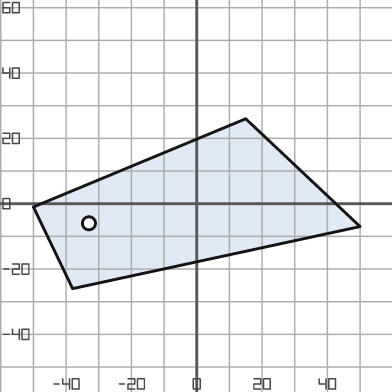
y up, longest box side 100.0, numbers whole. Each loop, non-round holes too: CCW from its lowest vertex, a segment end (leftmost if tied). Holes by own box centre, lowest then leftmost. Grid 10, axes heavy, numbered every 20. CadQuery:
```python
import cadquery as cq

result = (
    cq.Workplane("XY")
    .moveTo(-38.0, -26.0)
    .lineTo(50.0, -7.0)
    .lineTo(15.0, 26.0)
    .lineTo(-50.0, -1.0)
    .close()
    .moveTo(-33.0, -6.0)
    .circle(2.0)
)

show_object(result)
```